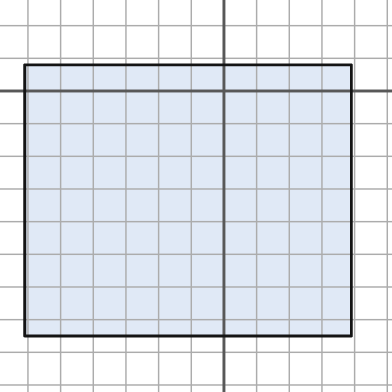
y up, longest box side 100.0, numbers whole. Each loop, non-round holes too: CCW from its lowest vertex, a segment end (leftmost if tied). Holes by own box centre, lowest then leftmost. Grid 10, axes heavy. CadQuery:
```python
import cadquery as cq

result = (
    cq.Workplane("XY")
    .moveTo(-61.0, -75.0)
    .lineTo(39.0, -75.0)
    .lineTo(39.0, 8.0)
    .lineTo(-61.0, 8.0)
    .close()
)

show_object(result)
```